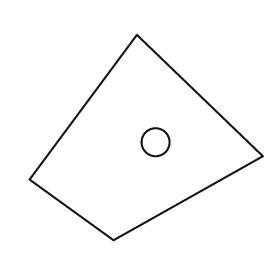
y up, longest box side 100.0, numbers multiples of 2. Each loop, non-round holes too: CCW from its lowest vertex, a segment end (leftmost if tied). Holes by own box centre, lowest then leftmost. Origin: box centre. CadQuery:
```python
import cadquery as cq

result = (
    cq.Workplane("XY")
    .moveTo(-14.0, -44.0)
    .lineTo(50.0, -8.0)
    .lineTo(-4.0, 44.0)
    .lineTo(-50.0, -18.0)
    .close()
    .moveTo(4.0, -2.0)
    .circle(6.0)
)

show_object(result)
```